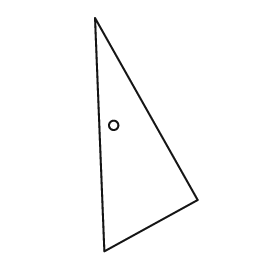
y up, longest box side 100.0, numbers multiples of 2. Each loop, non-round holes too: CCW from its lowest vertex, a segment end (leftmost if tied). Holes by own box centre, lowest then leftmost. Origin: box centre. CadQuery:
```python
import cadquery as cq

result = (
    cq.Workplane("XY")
    .moveTo(-18.0, -50.0)
    .lineTo(22.0, -28.0)
    .lineTo(-22.0, 50.0)
    .close()
    .moveTo(-14.0, 4.0)
    .circle(2.0)
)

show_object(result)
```